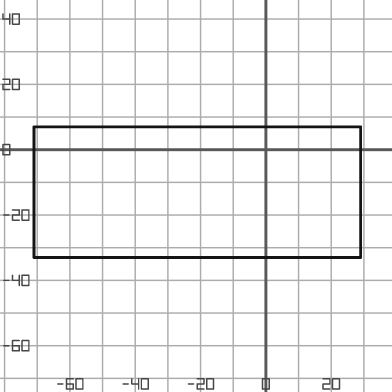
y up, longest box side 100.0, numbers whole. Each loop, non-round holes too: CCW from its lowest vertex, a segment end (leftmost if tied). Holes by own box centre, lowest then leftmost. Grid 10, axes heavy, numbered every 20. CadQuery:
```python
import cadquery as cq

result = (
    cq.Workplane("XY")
    .moveTo(-71.0, -33.0)
    .lineTo(29.0, -33.0)
    .lineTo(29.0, 7.0)
    .lineTo(-71.0, 7.0)
    .close()
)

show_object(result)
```